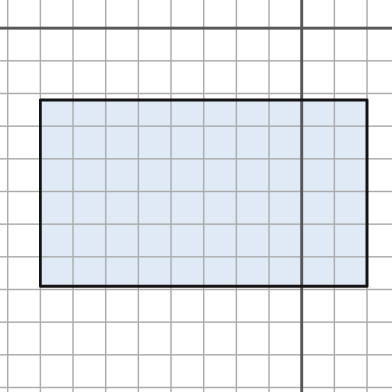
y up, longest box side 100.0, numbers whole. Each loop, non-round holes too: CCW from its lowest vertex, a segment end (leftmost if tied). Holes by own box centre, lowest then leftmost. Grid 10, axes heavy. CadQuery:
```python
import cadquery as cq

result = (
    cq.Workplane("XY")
    .moveTo(-80.0, -79.0)
    .lineTo(20.0, -79.0)
    .lineTo(20.0, -22.0)
    .lineTo(-80.0, -22.0)
    .close()
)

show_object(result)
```